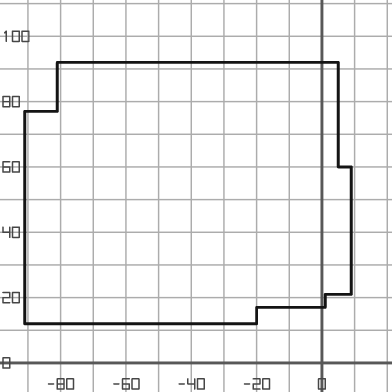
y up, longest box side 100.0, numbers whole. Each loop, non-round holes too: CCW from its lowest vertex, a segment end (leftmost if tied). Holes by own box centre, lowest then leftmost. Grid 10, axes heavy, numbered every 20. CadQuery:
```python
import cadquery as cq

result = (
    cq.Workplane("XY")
    .moveTo(-91.0, 12.0)
    .lineTo(-20.0, 12.0)
    .lineTo(-20.0, 17.0)
    .lineTo(1.0, 17.0)
    .lineTo(1.0, 21.0)
    .lineTo(9.0, 21.0)
    .lineTo(9.0, 60.0)
    .lineTo(5.0, 60.0)
    .lineTo(5.0, 92.0)
    .lineTo(-81.0, 92.0)
    .lineTo(-81.0, 77.0)
    .lineTo(-91.0, 77.0)
    .close()
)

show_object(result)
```